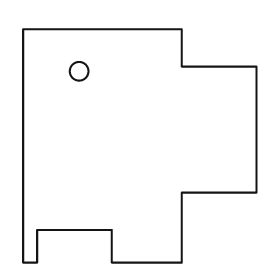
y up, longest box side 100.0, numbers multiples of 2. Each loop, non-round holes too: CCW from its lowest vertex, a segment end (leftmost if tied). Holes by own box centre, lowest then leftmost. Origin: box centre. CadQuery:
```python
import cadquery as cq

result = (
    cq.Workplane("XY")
    .moveTo(-50.0, -50.0)
    .lineTo(-44.0, -50.0)
    .lineTo(-44.0, -36.0)
    .lineTo(-12.0, -36.0)
    .lineTo(-12.0, -50.0)
    .lineTo(18.0, -50.0)
    .lineTo(18.0, -20.0)
    .lineTo(50.0, -20.0)
    .lineTo(50.0, 34.0)
    .lineTo(18.0, 34.0)
    .lineTo(18.0, 50.0)
    .lineTo(-50.0, 50.0)
    .close()
    .moveTo(-26.0, 32.0)
    .circle(4.0)
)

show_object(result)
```